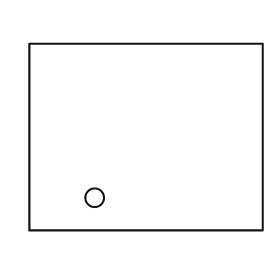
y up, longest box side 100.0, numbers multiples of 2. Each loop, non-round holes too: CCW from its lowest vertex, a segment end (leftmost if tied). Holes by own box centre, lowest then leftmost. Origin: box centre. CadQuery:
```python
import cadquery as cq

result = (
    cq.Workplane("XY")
    .moveTo(-50.0, -40.0)
    .lineTo(50.0, -40.0)
    .lineTo(50.0, 40.0)
    .lineTo(-50.0, 40.0)
    .close()
    .moveTo(-22.0, -26.0)
    .circle(4.0)
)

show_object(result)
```